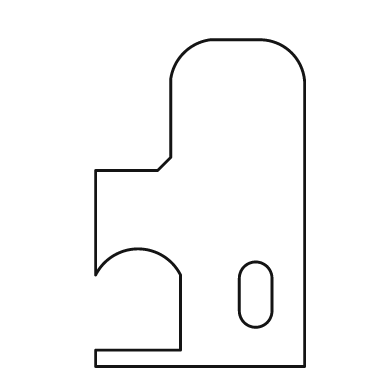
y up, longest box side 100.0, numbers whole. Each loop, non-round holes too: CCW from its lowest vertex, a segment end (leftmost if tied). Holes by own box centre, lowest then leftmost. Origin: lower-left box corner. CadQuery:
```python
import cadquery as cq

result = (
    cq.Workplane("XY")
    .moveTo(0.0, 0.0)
    .lineTo(64.0, 0.0)
    .lineTo(64.0, 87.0)
    .threePointArc((60.0, 96.0), (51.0, 100.0))
    .lineTo(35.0, 100.0)
    .threePointArc((27.0, 96.0), (23.0, 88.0))
    .lineTo(23.0, 64.0)
    .lineTo(19.0, 60.0)
    .lineTo(0.0, 60.0)
    .lineTo(0.0, 28.0)
    .threePointArc((13.0, 36.0), (26.0, 28.0))
    .lineTo(26.0, 5.0)
    .lineTo(0.0, 5.0)
    .close()
    .moveTo(44.0, 17.0)
    .threePointArc((49.0, 12.0), (54.0, 17.0))
    .lineTo(54.0, 27.0)
    .threePointArc((49.0, 32.0), (44.0, 27.0))
    .close()
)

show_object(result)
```